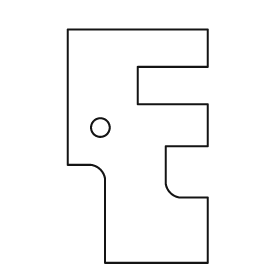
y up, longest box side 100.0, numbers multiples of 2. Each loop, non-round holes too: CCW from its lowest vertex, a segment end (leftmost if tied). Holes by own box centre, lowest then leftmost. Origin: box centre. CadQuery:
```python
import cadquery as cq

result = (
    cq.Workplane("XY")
    .moveTo(-14.0, -50.0)
    .lineTo(30.0, -50.0)
    .lineTo(30.0, -22.0)
    .lineTo(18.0, -22.0)
    .threePointArc((14.0, -20.0), (12.0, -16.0))
    .lineTo(12.0, 0.0)
    .lineTo(30.0, 0.0)
    .lineTo(30.0, 18.0)
    .lineTo(0.0, 18.0)
    .lineTo(0.0, 34.0)
    .lineTo(30.0, 34.0)
    .lineTo(30.0, 50.0)
    .lineTo(-30.0, 50.0)
    .lineTo(-30.0, -8.0)
    .lineTo(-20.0, -8.0)
    .threePointArc((-16.0, -10.0), (-14.0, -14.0))
    .close()
    .moveTo(-16.0, 8.0)
    .circle(4.0)
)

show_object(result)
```